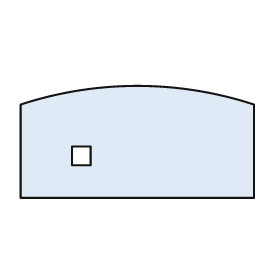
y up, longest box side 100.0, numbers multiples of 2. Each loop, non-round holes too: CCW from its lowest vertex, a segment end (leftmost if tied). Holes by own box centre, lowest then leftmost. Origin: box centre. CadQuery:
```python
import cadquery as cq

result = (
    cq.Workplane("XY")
    .moveTo(-50.0, -24.0)
    .lineTo(50.0, -24.0)
    .lineTo(50.0, 16.0)
    .threePointArc((0.0, 24.0), (-50.0, 16.0))
    .close()
    .moveTo(-28.0, -10.0)
    .lineTo(-20.0, -10.0)
    .lineTo(-20.0, -2.0)
    .lineTo(-28.0, -2.0)
    .close()
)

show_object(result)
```